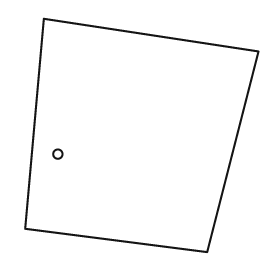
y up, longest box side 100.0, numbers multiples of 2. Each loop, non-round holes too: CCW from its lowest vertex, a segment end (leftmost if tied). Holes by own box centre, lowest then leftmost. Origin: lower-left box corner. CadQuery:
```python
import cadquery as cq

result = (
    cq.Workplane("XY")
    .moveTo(78.0, 0.0)
    .lineTo(100.0, 86.0)
    .lineTo(8.0, 100.0)
    .lineTo(0.0, 10.0)
    .close()
    .moveTo(14.0, 42.0)
    .circle(2.0)
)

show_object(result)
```